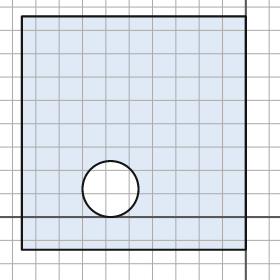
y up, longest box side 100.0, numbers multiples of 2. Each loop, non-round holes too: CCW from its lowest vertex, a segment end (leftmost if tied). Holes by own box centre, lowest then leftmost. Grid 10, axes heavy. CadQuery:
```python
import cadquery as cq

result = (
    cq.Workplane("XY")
    .moveTo(-96.0, -14.0)
    .lineTo(0.0, -14.0)
    .lineTo(0.0, 86.0)
    .lineTo(-96.0, 86.0)
    .close()
    .moveTo(-58.0, 12.0)
    .circle(12.0)
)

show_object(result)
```